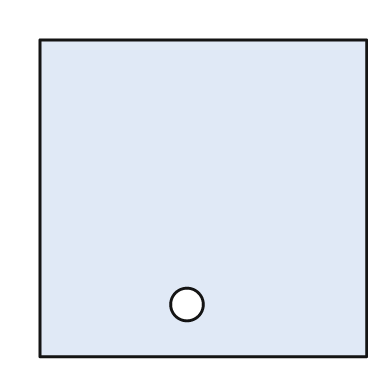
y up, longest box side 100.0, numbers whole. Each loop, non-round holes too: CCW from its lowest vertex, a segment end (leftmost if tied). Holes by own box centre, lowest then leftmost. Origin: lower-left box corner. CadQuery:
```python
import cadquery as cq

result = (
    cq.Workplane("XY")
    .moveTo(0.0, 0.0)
    .lineTo(100.0, 0.0)
    .lineTo(100.0, 97.0)
    .lineTo(0.0, 97.0)
    .close()
    .moveTo(45.0, 16.0)
    .circle(5.0)
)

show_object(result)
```